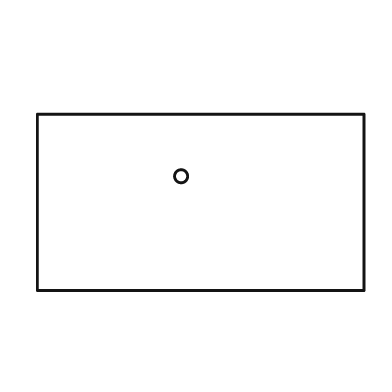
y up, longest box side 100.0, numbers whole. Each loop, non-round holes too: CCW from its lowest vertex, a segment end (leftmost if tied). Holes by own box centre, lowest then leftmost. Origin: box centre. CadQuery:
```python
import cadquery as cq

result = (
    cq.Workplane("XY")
    .moveTo(-50.0, -27.0)
    .lineTo(50.0, -27.0)
    .lineTo(50.0, 27.0)
    .lineTo(-50.0, 27.0)
    .close()
    .moveTo(-6.0, 8.0)
    .circle(2.0)
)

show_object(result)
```